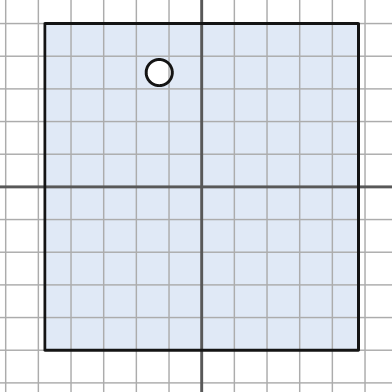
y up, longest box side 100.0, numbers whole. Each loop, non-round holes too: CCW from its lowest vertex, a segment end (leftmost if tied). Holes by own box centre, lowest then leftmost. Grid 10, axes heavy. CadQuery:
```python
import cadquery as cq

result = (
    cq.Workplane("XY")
    .moveTo(-48.0, -50.0)
    .lineTo(48.0, -50.0)
    .lineTo(48.0, 50.0)
    .lineTo(-48.0, 50.0)
    .close()
    .moveTo(-13.0, 35.0)
    .circle(4.0)
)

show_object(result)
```